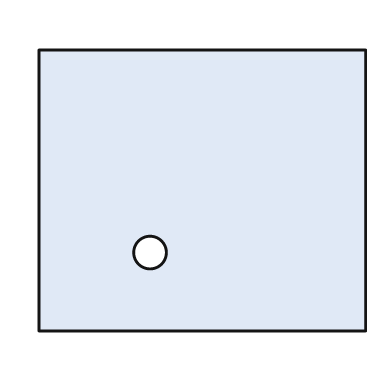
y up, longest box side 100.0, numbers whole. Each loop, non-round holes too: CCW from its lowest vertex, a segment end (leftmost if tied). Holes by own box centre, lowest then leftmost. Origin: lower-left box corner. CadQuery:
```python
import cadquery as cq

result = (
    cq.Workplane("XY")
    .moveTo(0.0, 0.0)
    .lineTo(100.0, 0.0)
    .lineTo(100.0, 86.0)
    .lineTo(0.0, 86.0)
    .close()
    .moveTo(34.0, 24.0)
    .circle(5.0)
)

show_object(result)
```